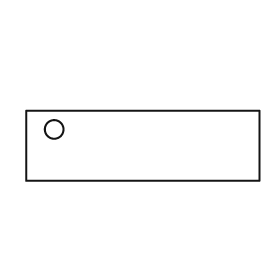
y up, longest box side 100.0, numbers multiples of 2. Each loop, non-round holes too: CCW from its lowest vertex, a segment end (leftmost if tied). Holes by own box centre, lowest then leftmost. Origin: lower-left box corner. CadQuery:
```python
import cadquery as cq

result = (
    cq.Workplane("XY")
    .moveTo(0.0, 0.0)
    .lineTo(100.0, 0.0)
    .lineTo(100.0, 30.0)
    .lineTo(0.0, 30.0)
    .close()
    .moveTo(12.0, 22.0)
    .circle(4.0)
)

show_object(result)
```